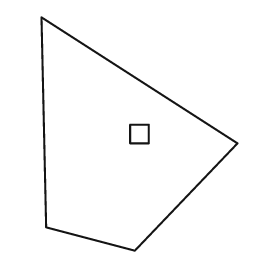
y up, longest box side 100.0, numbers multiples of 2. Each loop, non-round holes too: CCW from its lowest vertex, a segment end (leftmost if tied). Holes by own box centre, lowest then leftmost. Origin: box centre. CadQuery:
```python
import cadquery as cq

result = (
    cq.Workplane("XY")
    .moveTo(-2.0, -50.0)
    .lineTo(42.0, -4.0)
    .lineTo(-42.0, 50.0)
    .lineTo(-40.0, -40.0)
    .close()
    .moveTo(-4.0, -4.0)
    .lineTo(4.0, -4.0)
    .lineTo(4.0, 4.0)
    .lineTo(-4.0, 4.0)
    .close()
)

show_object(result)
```